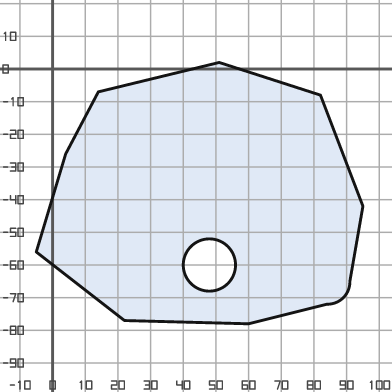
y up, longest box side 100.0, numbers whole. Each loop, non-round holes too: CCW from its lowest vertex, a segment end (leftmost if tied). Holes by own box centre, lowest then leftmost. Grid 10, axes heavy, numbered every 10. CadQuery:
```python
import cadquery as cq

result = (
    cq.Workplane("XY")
    .moveTo(60.0, -78.0)
    .lineTo(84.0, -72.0)
    .threePointArc((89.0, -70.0), (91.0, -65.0))
    .lineTo(95.0, -42.0)
    .lineTo(82.0, -8.0)
    .lineTo(51.0, 2.0)
    .lineTo(14.0, -7.0)
    .lineTo(4.0, -26.0)
    .lineTo(-5.0, -56.0)
    .lineTo(22.0, -77.0)
    .close()
    .moveTo(48.0, -60.0)
    .circle(8.0)
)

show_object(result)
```